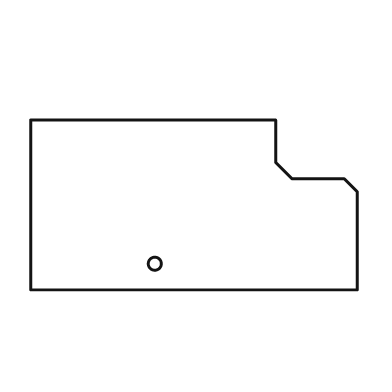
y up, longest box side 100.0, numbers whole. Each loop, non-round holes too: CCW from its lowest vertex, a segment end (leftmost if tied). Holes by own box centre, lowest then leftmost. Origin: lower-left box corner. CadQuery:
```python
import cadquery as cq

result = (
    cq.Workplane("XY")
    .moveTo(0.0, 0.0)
    .lineTo(100.0, 0.0)
    .lineTo(100.0, 30.0)
    .lineTo(96.0, 34.0)
    .lineTo(80.0, 34.0)
    .lineTo(75.0, 39.0)
    .lineTo(75.0, 52.0)
    .lineTo(0.0, 52.0)
    .close()
    .moveTo(38.0, 8.0)
    .circle(2.0)
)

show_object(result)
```